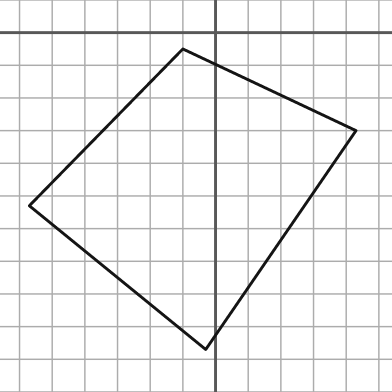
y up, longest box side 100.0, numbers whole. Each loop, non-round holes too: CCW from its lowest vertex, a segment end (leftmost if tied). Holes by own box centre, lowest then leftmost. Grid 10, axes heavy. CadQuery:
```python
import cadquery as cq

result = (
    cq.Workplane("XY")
    .moveTo(-3.0, -97.0)
    .lineTo(43.0, -30.0)
    .lineTo(-10.0, -5.0)
    .lineTo(-57.0, -53.0)
    .close()
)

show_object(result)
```